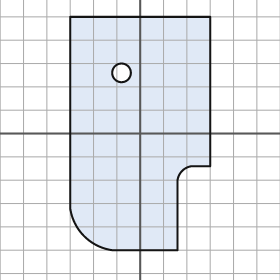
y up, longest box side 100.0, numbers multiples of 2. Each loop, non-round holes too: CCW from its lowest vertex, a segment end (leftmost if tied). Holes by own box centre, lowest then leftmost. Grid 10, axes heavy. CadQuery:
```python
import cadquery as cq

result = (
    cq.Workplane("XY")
    .moveTo(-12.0, -50.0)
    .lineTo(16.0, -50.0)
    .lineTo(16.0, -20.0)
    .threePointArc((18.0, -16.0), (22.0, -14.0))
    .lineTo(30.0, -14.0)
    .lineTo(30.0, 50.0)
    .lineTo(-30.0, 50.0)
    .lineTo(-30.0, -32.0)
    .threePointArc((-24.0, -44.0), (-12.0, -50.0))
    .close()
    .moveTo(-8.0, 26.0)
    .circle(4.0)
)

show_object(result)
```